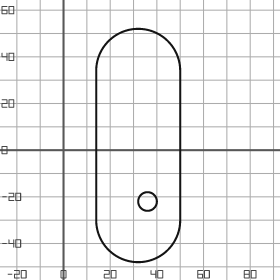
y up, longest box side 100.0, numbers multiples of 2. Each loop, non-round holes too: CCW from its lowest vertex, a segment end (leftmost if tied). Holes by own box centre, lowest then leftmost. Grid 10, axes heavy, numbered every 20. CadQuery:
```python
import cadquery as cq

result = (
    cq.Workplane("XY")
    .moveTo(14.0, -30.0)
    .threePointArc((32.0, -48.0), (50.0, -30.0))
    .lineTo(50.0, 34.0)
    .threePointArc((32.0, 52.0), (14.0, 34.0))
    .close()
    .moveTo(36.0, -22.0)
    .circle(4.0)
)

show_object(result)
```